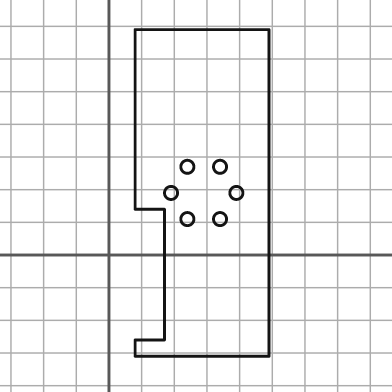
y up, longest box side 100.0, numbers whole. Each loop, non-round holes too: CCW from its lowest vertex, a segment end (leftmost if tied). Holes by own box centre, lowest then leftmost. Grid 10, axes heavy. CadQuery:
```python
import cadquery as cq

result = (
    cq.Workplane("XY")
    .moveTo(8.0, -31.0)
    .lineTo(49.0, -31.0)
    .lineTo(49.0, 69.0)
    .lineTo(8.0, 69.0)
    .lineTo(8.0, 14.0)
    .lineTo(17.0, 14.0)
    .lineTo(17.0, -26.0)
    .lineTo(8.0, -26.0)
    .close()
    .moveTo(24.0, 11.0)
    .circle(2.0)
    .moveTo(34.0, 11.0)
    .circle(2.0)
    .moveTo(19.0, 19.0)
    .circle(2.0)
    .moveTo(39.0, 19.0)
    .circle(2.0)
    .moveTo(24.0, 27.0)
    .circle(2.0)
    .moveTo(34.0, 27.0)
    .circle(2.0)
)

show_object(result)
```